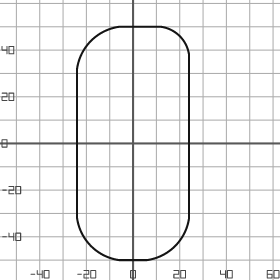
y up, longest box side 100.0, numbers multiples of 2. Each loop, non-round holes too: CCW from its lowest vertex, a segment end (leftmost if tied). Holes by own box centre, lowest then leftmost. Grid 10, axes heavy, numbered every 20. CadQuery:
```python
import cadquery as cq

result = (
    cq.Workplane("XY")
    .moveTo(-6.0, -50.0)
    .lineTo(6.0, -50.0)
    .threePointArc((18.0, -44.0), (24.0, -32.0))
    .lineTo(24.0, 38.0)
    .threePointArc((20.0, 46.0), (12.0, 50.0))
    .lineTo(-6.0, 50.0)
    .threePointArc((-18.0, 44.0), (-24.0, 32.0))
    .lineTo(-24.0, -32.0)
    .threePointArc((-18.0, -44.0), (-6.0, -50.0))
    .close()
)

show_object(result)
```